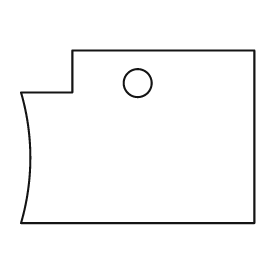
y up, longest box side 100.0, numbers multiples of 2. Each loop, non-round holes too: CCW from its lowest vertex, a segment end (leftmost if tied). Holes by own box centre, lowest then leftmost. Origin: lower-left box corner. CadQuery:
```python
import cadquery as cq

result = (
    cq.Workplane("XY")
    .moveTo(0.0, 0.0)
    .lineTo(100.0, 0.0)
    .lineTo(100.0, 74.0)
    .lineTo(22.0, 74.0)
    .lineTo(22.0, 56.0)
    .lineTo(0.0, 56.0)
    .threePointArc((4.0, 28.0), (0.0, 0.0))
    .close()
    .moveTo(50.0, 60.0)
    .circle(6.0)
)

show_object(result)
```